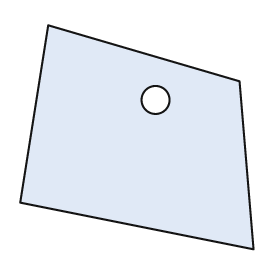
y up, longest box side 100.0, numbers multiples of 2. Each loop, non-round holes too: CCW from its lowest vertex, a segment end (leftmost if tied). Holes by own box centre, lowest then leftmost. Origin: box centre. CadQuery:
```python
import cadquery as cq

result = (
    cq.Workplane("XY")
    .moveTo(50.0, -48.0)
    .lineTo(44.0, 24.0)
    .lineTo(-38.0, 48.0)
    .lineTo(-50.0, -28.0)
    .close()
    .moveTo(8.0, 16.0)
    .circle(6.0)
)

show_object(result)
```